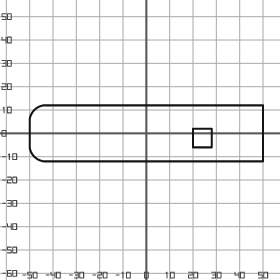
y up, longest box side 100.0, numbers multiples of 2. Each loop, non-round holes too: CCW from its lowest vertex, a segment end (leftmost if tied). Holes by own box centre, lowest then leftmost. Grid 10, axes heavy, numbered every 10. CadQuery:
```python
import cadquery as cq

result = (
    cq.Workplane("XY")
    .moveTo(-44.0, -12.0)
    .lineTo(50.0, -12.0)
    .lineTo(50.0, 12.0)
    .lineTo(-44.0, 12.0)
    .threePointArc((-48.0, 10.0), (-50.0, 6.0))
    .lineTo(-50.0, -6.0)
    .threePointArc((-48.0, -10.0), (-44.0, -12.0))
    .close()
    .moveTo(20.0, -6.0)
    .lineTo(28.0, -6.0)
    .lineTo(28.0, 2.0)
    .lineTo(20.0, 2.0)
    .close()
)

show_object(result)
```